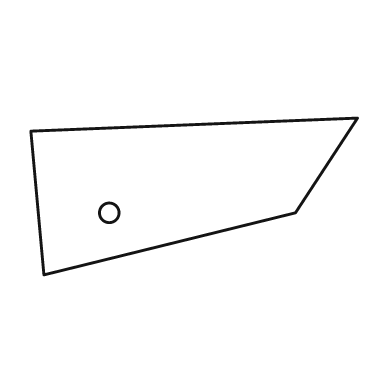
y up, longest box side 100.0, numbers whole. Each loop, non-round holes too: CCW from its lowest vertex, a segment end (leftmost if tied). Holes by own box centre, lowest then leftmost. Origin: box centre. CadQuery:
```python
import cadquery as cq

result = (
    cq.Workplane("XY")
    .moveTo(-46.0, -24.0)
    .lineTo(31.0, -5.0)
    .lineTo(50.0, 24.0)
    .lineTo(-50.0, 20.0)
    .close()
    .moveTo(-26.0, -5.0)
    .circle(3.0)
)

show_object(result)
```